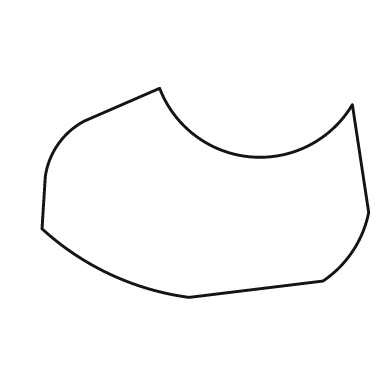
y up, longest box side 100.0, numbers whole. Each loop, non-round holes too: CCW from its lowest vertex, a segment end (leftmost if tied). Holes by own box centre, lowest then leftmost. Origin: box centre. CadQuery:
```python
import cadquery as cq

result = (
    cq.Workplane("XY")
    .moveTo(-5.0, -32.0)
    .lineTo(36.0, -27.0)
    .threePointArc((45.0, -18.0), (50.0, -6.0))
    .lineTo(45.0, 27.0)
    .threePointArc((14.0, 11.0), (-14.0, 32.0))
    .lineTo(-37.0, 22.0)
    .threePointArc((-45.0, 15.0), (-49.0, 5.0))
    .lineTo(-50.0, -11.0)
    .threePointArc((-29.0, -25.0), (-5.0, -32.0))
    .close()
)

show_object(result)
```